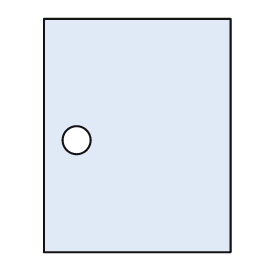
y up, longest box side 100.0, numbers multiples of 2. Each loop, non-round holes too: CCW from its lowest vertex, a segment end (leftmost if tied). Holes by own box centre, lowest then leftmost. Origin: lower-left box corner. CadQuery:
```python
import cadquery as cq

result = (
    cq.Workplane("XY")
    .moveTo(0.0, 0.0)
    .lineTo(80.0, 0.0)
    .lineTo(80.0, 100.0)
    .lineTo(0.0, 100.0)
    .close()
    .moveTo(14.0, 48.0)
    .circle(6.0)
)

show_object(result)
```